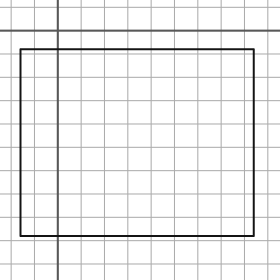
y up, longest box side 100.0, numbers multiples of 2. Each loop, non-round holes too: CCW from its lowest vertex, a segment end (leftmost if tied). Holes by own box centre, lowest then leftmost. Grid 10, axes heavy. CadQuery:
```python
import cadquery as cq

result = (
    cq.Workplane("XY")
    .moveTo(-16.0, -88.0)
    .lineTo(84.0, -88.0)
    .lineTo(84.0, -8.0)
    .lineTo(-16.0, -8.0)
    .close()
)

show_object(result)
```